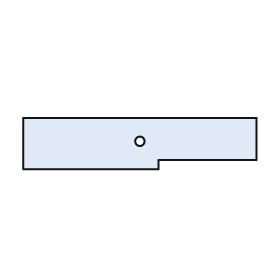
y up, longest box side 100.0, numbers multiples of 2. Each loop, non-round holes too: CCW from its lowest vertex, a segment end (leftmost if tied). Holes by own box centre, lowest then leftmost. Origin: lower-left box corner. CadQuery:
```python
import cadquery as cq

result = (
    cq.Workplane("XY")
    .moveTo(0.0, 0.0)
    .lineTo(58.0, 0.0)
    .lineTo(58.0, 4.0)
    .lineTo(100.0, 4.0)
    .lineTo(100.0, 22.0)
    .lineTo(0.0, 22.0)
    .close()
    .moveTo(50.0, 12.0)
    .circle(2.0)
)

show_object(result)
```